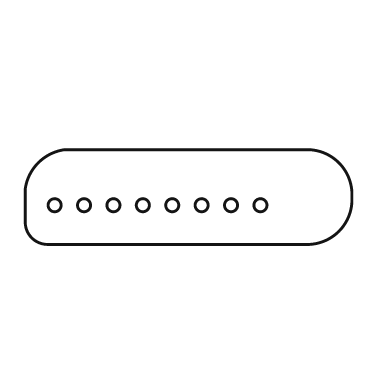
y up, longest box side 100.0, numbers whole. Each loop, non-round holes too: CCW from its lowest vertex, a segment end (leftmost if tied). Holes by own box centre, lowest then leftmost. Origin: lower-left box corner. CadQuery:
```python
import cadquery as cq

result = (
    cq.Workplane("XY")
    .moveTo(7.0, 0.0)
    .lineTo(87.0, 0.0)
    .threePointArc((96.0, 4.0), (100.0, 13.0))
    .lineTo(100.0, 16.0)
    .threePointArc((96.0, 25.0), (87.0, 29.0))
    .lineTo(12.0, 29.0)
    .threePointArc((4.0, 25.0), (0.0, 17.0))
    .lineTo(0.0, 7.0)
    .threePointArc((2.0, 2.0), (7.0, 0.0))
    .close()
    .moveTo(9.0, 12.0)
    .circle(2.0)
    .moveTo(18.0, 12.0)
    .circle(2.0)
    .moveTo(27.0, 12.0)
    .circle(2.0)
    .moveTo(36.0, 12.0)
    .circle(2.0)
    .moveTo(45.0, 12.0)
    .circle(2.0)
    .moveTo(54.0, 12.0)
    .circle(2.0)
    .moveTo(63.0, 12.0)
    .circle(2.0)
    .moveTo(72.0, 12.0)
    .circle(2.0)
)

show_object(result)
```